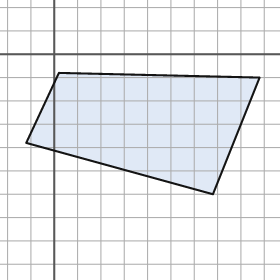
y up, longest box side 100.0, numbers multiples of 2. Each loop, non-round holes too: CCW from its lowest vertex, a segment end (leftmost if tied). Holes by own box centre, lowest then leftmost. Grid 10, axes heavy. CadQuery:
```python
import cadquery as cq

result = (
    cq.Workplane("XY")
    .moveTo(68.0, -60.0)
    .lineTo(88.0, -10.0)
    .lineTo(2.0, -8.0)
    .lineTo(-12.0, -38.0)
    .close()
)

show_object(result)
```